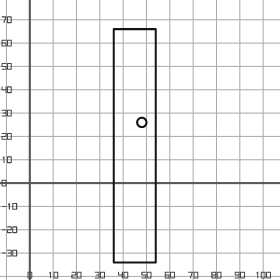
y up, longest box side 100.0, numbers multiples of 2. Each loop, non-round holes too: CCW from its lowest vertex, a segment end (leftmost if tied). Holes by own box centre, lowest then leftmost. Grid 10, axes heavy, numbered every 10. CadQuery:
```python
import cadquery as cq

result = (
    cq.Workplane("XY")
    .moveTo(36.0, -34.0)
    .lineTo(54.0, -34.0)
    .lineTo(54.0, 66.0)
    .lineTo(36.0, 66.0)
    .close()
    .moveTo(48.0, 26.0)
    .circle(2.0)
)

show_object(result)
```